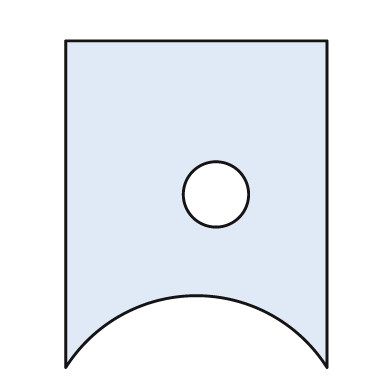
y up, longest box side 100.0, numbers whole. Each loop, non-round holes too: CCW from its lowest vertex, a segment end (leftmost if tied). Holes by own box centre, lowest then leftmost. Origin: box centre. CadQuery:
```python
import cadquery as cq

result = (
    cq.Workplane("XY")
    .moveTo(-40.0, -50.0)
    .threePointArc((0.0, -28.0), (40.0, -50.0))
    .lineTo(40.0, 50.0)
    .lineTo(-40.0, 50.0)
    .close()
    .moveTo(6.0, 3.0)
    .circle(10.0)
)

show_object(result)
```